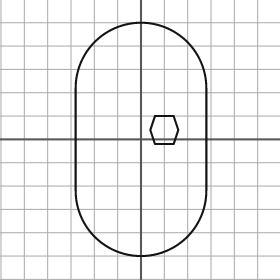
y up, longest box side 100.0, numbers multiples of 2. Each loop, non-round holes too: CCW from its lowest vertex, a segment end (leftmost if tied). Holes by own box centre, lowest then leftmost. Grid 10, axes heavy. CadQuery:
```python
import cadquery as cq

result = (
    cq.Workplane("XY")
    .moveTo(-28.0, -22.0)
    .threePointArc((0.0, -50.0), (28.0, -22.0))
    .lineTo(28.0, 22.0)
    .threePointArc((0.0, 50.0), (-28.0, 22.0))
    .close()
    .moveTo(6.0, -2.0)
    .lineTo(14.0, -2.0)
    .lineTo(16.0, 4.0)
    .lineTo(14.0, 10.0)
    .lineTo(6.0, 10.0)
    .lineTo(4.0, 4.0)
    .close()
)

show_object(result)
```